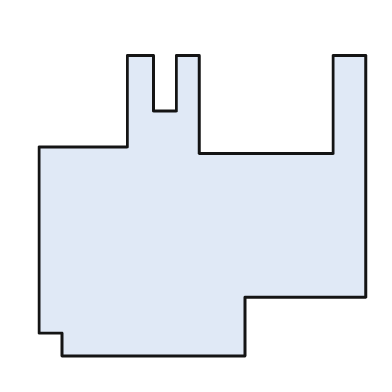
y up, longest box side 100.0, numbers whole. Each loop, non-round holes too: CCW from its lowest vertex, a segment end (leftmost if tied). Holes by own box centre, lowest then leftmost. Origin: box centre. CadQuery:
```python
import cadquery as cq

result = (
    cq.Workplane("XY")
    .moveTo(-43.0, -46.0)
    .lineTo(13.0, -46.0)
    .lineTo(13.0, -28.0)
    .lineTo(50.0, -28.0)
    .lineTo(50.0, 46.0)
    .lineTo(40.0, 46.0)
    .lineTo(40.0, 16.0)
    .lineTo(-1.0, 16.0)
    .lineTo(-1.0, 46.0)
    .lineTo(-8.0, 46.0)
    .lineTo(-8.0, 29.0)
    .lineTo(-15.0, 29.0)
    .lineTo(-15.0, 46.0)
    .lineTo(-23.0, 46.0)
    .lineTo(-23.0, 18.0)
    .lineTo(-50.0, 18.0)
    .lineTo(-50.0, -39.0)
    .lineTo(-43.0, -39.0)
    .close()
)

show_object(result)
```